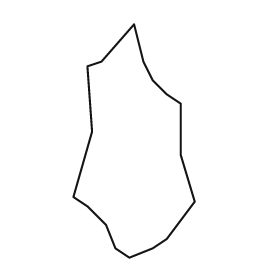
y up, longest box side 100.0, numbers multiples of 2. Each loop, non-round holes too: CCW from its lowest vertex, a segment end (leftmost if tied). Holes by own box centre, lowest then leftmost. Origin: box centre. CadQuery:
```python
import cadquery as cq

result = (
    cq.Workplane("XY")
    .moveTo(-2.0, -50.0)
    .lineTo(8.0, -46.0)
    .lineTo(14.0, -42.0)
    .lineTo(26.0, -26.0)
    .lineTo(20.0, -6.0)
    .lineTo(20.0, 16.0)
    .lineTo(14.0, 20.0)
    .lineTo(8.0, 26.0)
    .lineTo(4.0, 34.0)
    .lineTo(0.0, 50.0)
    .lineTo(-14.0, 34.0)
    .lineTo(-20.0, 32.0)
    .lineTo(-18.0, 4.0)
    .lineTo(-26.0, -24.0)
    .lineTo(-20.0, -28.0)
    .lineTo(-12.0, -36.0)
    .lineTo(-8.0, -46.0)
    .close()
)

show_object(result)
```